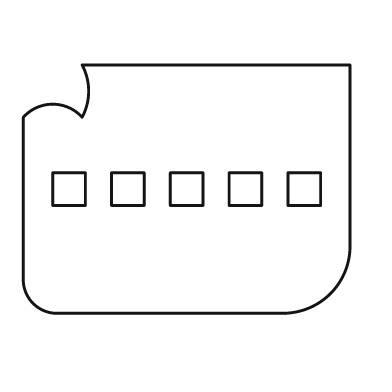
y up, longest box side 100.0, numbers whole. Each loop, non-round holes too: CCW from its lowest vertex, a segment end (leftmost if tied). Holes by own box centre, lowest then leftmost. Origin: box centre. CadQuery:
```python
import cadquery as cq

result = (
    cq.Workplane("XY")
    .moveTo(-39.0, -38.0)
    .lineTo(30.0, -38.0)
    .threePointArc((44.0, -32.0), (50.0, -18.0))
    .lineTo(50.0, 38.0)
    .lineTo(-32.0, 38.0)
    .threePointArc((-30.0, 30.0), (-32.0, 22.0))
    .threePointArc((-41.0, 26.0), (-50.0, 22.0))
    .lineTo(-50.0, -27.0)
    .threePointArc((-47.0, -35.0), (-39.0, -38.0))
    .close()
    .moveTo(-41.0, -5.0)
    .lineTo(-31.0, -5.0)
    .lineTo(-31.0, 5.0)
    .lineTo(-41.0, 5.0)
    .close()
    .moveTo(-23.0, -5.0)
    .lineTo(-13.0, -5.0)
    .lineTo(-13.0, 5.0)
    .lineTo(-23.0, 5.0)
    .close()
    .moveTo(-5.0, -5.0)
    .lineTo(5.0, -5.0)
    .lineTo(5.0, 5.0)
    .lineTo(-5.0, 5.0)
    .close()
    .moveTo(13.0, -5.0)
    .lineTo(23.0, -5.0)
    .lineTo(23.0, 5.0)
    .lineTo(13.0, 5.0)
    .close()
    .moveTo(31.0, -5.0)
    .lineTo(41.0, -5.0)
    .lineTo(41.0, 5.0)
    .lineTo(31.0, 5.0)
    .close()
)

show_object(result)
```